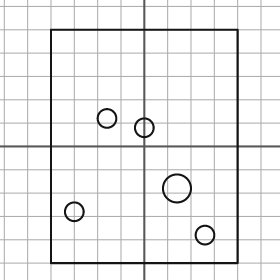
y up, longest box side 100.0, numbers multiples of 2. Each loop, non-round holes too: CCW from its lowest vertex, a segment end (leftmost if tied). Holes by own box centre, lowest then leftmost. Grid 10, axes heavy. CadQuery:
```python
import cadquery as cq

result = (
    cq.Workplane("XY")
    .moveTo(-40.0, -50.0)
    .lineTo(40.0, -50.0)
    .lineTo(40.0, 50.0)
    .lineTo(-40.0, 50.0)
    .close()
    .moveTo(26.0, -38.0)
    .circle(4.0)
    .moveTo(-30.0, -28.0)
    .circle(4.0)
    .moveTo(14.0, -18.0)
    .circle(6.0)
    .moveTo(0.0, 8.0)
    .circle(4.0)
    .moveTo(-16.0, 12.0)
    .circle(4.0)
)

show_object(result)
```